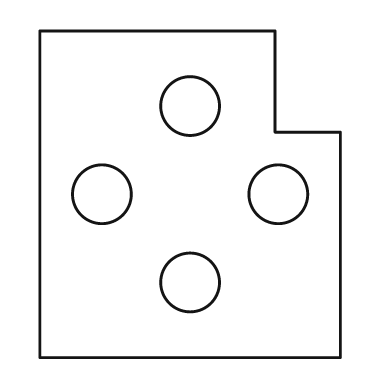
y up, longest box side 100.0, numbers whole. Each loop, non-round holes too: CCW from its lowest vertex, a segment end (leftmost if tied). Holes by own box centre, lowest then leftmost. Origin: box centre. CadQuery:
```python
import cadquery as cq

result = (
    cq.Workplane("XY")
    .moveTo(-46.0, -50.0)
    .lineTo(46.0, -50.0)
    .lineTo(46.0, 19.0)
    .lineTo(26.0, 19.0)
    .lineTo(26.0, 50.0)
    .lineTo(-46.0, 50.0)
    .close()
    .moveTo(0.0, -27.0)
    .circle(9.0)
    .moveTo(-27.0, 0.0)
    .circle(9.0)
    .moveTo(27.0, 0.0)
    .circle(9.0)
    .moveTo(0.0, 27.0)
    .circle(9.0)
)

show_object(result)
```